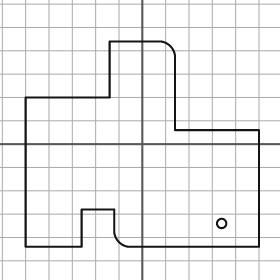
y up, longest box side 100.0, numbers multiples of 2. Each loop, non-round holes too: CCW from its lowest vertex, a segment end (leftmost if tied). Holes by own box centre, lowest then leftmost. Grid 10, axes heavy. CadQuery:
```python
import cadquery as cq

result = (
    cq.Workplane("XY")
    .moveTo(-50.0, -44.0)
    .lineTo(-26.0, -44.0)
    .lineTo(-26.0, -28.0)
    .lineTo(-12.0, -28.0)
    .lineTo(-12.0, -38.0)
    .threePointArc((-10.0, -42.0), (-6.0, -44.0))
    .lineTo(50.0, -44.0)
    .lineTo(50.0, 6.0)
    .lineTo(14.0, 6.0)
    .lineTo(14.0, 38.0)
    .threePointArc((12.0, 42.0), (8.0, 44.0))
    .lineTo(-14.0, 44.0)
    .lineTo(-14.0, 20.0)
    .lineTo(-50.0, 20.0)
    .close()
    .moveTo(34.0, -34.0)
    .circle(2.0)
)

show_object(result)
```